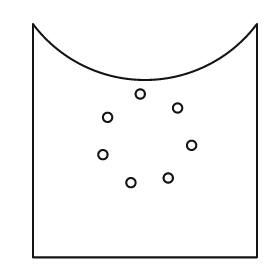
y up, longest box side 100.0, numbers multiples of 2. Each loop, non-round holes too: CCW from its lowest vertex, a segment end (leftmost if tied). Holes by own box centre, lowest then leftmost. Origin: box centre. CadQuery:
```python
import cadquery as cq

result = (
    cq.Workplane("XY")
    .moveTo(-48.0, -50.0)
    .lineTo(48.0, -50.0)
    .lineTo(48.0, 50.0)
    .threePointArc((0.0, 26.0), (-48.0, 50.0))
    .close()
    .moveTo(-6.0, -18.0)
    .circle(2.0)
    .moveTo(10.0, -16.0)
    .circle(2.0)
    .moveTo(-18.0, -6.0)
    .circle(2.0)
    .moveTo(20.0, -2.0)
    .circle(2.0)
    .moveTo(-16.0, 10.0)
    .circle(2.0)
    .moveTo(14.0, 14.0)
    .circle(2.0)
    .moveTo(-2.0, 20.0)
    .circle(2.0)
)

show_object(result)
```